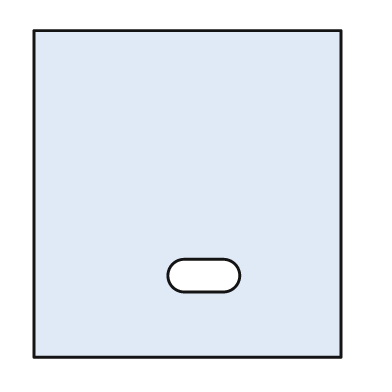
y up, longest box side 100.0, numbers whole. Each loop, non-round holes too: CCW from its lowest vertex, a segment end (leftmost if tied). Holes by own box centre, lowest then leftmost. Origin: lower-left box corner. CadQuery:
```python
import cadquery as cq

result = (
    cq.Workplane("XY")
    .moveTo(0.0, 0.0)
    .lineTo(94.0, 0.0)
    .lineTo(94.0, 100.0)
    .lineTo(0.0, 100.0)
    .close()
    .moveTo(46.0, 20.0)
    .lineTo(58.0, 20.0)
    .threePointArc((63.0, 25.0), (58.0, 30.0))
    .lineTo(46.0, 30.0)
    .threePointArc((41.0, 25.0), (46.0, 20.0))
    .close()
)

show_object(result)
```